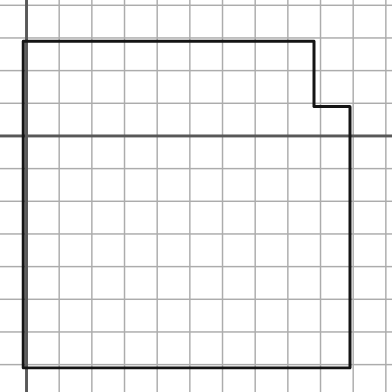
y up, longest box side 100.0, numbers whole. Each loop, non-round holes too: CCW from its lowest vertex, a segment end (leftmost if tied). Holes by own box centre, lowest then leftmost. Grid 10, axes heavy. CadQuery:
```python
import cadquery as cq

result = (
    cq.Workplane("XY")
    .moveTo(-1.0, -71.0)
    .lineTo(99.0, -71.0)
    .lineTo(99.0, 9.0)
    .lineTo(88.0, 9.0)
    .lineTo(88.0, 29.0)
    .lineTo(-1.0, 29.0)
    .close()
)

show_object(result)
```